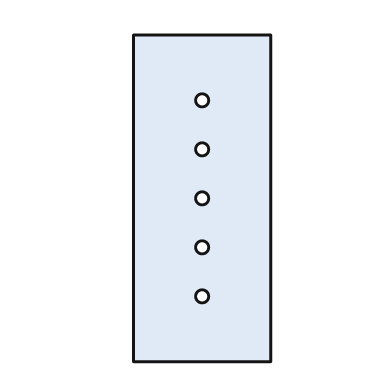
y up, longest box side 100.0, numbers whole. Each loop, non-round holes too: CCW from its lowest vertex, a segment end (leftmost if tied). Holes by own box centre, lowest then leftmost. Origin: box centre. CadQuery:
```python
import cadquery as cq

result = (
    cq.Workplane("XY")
    .moveTo(-21.0, -50.0)
    .lineTo(21.0, -50.0)
    .lineTo(21.0, 50.0)
    .lineTo(-21.0, 50.0)
    .close()
    .moveTo(0.0, -30.0)
    .circle(2.0)
    .moveTo(0.0, -15.0)
    .circle(2.0)
    .moveTo(0.0, 0.0)
    .circle(2.0)
    .moveTo(0.0, 15.0)
    .circle(2.0)
    .moveTo(0.0, 30.0)
    .circle(2.0)
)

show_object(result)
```